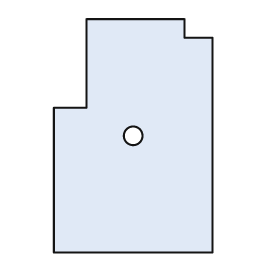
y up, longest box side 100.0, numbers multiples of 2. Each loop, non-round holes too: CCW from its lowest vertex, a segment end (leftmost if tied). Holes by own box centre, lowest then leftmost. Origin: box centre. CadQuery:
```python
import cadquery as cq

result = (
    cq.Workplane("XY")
    .moveTo(-34.0, -50.0)
    .lineTo(34.0, -50.0)
    .lineTo(34.0, 42.0)
    .lineTo(22.0, 42.0)
    .lineTo(22.0, 50.0)
    .lineTo(-20.0, 50.0)
    .lineTo(-20.0, 12.0)
    .lineTo(-34.0, 12.0)
    .close()
    .moveTo(0.0, 0.0)
    .circle(4.0)
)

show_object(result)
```